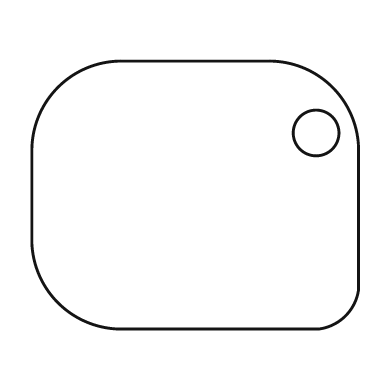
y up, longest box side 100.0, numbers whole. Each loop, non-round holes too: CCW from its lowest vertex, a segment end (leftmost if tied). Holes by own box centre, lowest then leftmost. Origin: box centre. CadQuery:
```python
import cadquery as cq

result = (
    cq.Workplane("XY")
    .moveTo(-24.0, -41.0)
    .lineTo(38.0, -41.0)
    .threePointArc((46.0, -37.0), (50.0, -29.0))
    .lineTo(50.0, 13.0)
    .threePointArc((42.0, 33.0), (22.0, 41.0))
    .lineTo(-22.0, 41.0)
    .threePointArc((-42.0, 33.0), (-50.0, 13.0))
    .lineTo(-50.0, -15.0)
    .threePointArc((-42.0, -33.0), (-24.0, -41.0))
    .close()
    .moveTo(37.0, 19.0)
    .circle(7.0)
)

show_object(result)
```